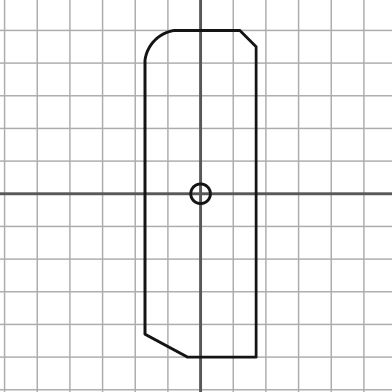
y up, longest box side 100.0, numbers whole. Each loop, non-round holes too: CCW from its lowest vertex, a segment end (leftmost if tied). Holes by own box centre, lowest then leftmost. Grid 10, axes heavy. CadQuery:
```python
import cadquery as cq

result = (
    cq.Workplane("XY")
    .moveTo(-4.0, -50.0)
    .lineTo(17.0, -50.0)
    .lineTo(17.0, 45.0)
    .lineTo(12.0, 50.0)
    .lineTo(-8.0, 50.0)
    .threePointArc((-14.0, 47.0), (-17.0, 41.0))
    .lineTo(-17.0, -43.0)
    .close()
    .moveTo(0.0, 0.0)
    .circle(3.0)
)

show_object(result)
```